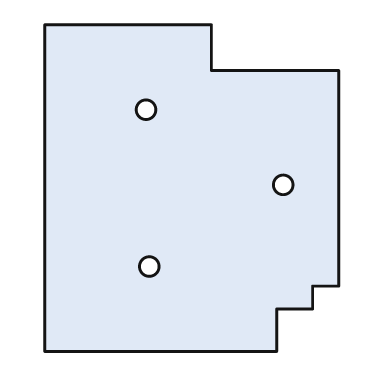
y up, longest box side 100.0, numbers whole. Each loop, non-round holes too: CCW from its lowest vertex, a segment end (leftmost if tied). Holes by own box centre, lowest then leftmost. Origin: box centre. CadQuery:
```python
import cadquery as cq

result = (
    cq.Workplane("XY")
    .moveTo(-45.0, -50.0)
    .lineTo(26.0, -50.0)
    .lineTo(26.0, -37.0)
    .lineTo(37.0, -37.0)
    .lineTo(37.0, -30.0)
    .lineTo(45.0, -30.0)
    .lineTo(45.0, 36.0)
    .lineTo(6.0, 36.0)
    .lineTo(6.0, 50.0)
    .lineTo(-45.0, 50.0)
    .close()
    .moveTo(-13.0, -24.0)
    .circle(3.0)
    .moveTo(28.0, 1.0)
    .circle(3.0)
    .moveTo(-14.0, 24.0)
    .circle(3.0)
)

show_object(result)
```